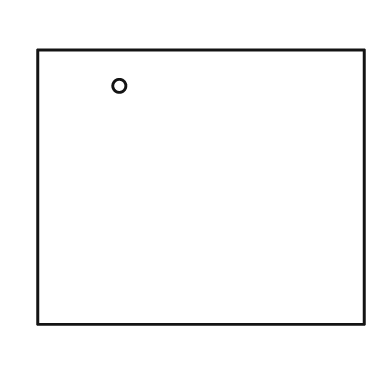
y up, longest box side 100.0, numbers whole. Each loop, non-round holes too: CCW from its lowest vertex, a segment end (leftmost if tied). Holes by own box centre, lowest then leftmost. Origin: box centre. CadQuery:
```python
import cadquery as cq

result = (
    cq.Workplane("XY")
    .moveTo(-50.0, -42.0)
    .lineTo(50.0, -42.0)
    .lineTo(50.0, 42.0)
    .lineTo(-50.0, 42.0)
    .close()
    .moveTo(-25.0, 31.0)
    .circle(2.0)
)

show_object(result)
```